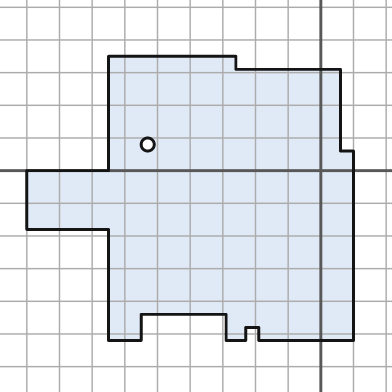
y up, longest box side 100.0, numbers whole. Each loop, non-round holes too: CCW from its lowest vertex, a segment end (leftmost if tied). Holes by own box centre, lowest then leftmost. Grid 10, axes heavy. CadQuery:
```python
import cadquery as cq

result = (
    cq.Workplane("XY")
    .moveTo(-65.0, -52.0)
    .lineTo(-55.0, -52.0)
    .lineTo(-55.0, -44.0)
    .lineTo(-29.0, -44.0)
    .lineTo(-29.0, -52.0)
    .lineTo(-23.0, -52.0)
    .lineTo(-23.0, -48.0)
    .lineTo(-19.0, -48.0)
    .lineTo(-19.0, -52.0)
    .lineTo(10.0, -52.0)
    .lineTo(10.0, 6.0)
    .lineTo(6.0, 6.0)
    .lineTo(6.0, 31.0)
    .lineTo(-26.0, 31.0)
    .lineTo(-26.0, 35.0)
    .lineTo(-65.0, 35.0)
    .lineTo(-65.0, 0.0)
    .lineTo(-90.0, 0.0)
    .lineTo(-90.0, -18.0)
    .lineTo(-65.0, -18.0)
    .close()
    .moveTo(-53.0, 8.0)
    .circle(2.0)
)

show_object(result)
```